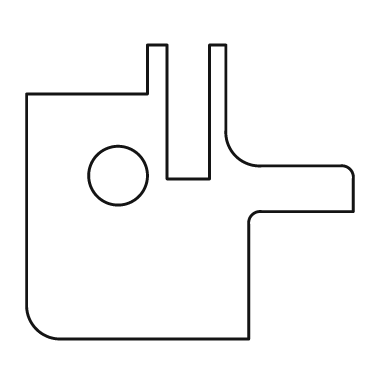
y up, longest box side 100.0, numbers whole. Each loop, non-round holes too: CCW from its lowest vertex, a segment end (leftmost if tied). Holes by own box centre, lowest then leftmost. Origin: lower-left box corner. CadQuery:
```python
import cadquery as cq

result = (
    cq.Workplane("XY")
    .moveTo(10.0, 0.0)
    .lineTo(68.0, 0.0)
    .lineTo(68.0, 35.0)
    .threePointArc((69.0, 38.0), (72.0, 39.0))
    .lineTo(100.0, 39.0)
    .lineTo(100.0, 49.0)
    .threePointArc((99.0, 52.0), (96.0, 53.0))
    .lineTo(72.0, 53.0)
    .threePointArc((64.0, 56.0), (61.0, 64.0))
    .lineTo(61.0, 90.0)
    .lineTo(56.0, 90.0)
    .lineTo(56.0, 49.0)
    .lineTo(43.0, 49.0)
    .lineTo(43.0, 90.0)
    .lineTo(37.0, 90.0)
    .lineTo(37.0, 75.0)
    .lineTo(0.0, 75.0)
    .lineTo(0.0, 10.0)
    .threePointArc((3.0, 3.0), (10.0, 0.0))
    .close()
    .moveTo(28.0, 50.0)
    .circle(9.0)
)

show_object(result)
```